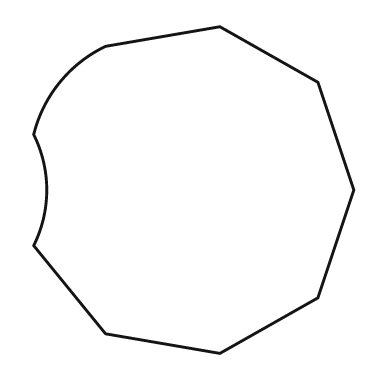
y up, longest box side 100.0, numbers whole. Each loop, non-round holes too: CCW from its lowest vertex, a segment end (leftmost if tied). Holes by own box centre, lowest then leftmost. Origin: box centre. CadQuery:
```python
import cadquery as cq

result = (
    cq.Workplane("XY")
    .moveTo(8.0, -50.0)
    .lineTo(38.0, -33.0)
    .lineTo(49.0, 0.0)
    .lineTo(38.0, 33.0)
    .lineTo(8.0, 50.0)
    .lineTo(-27.0, 44.0)
    .threePointArc((-41.0, 33.0), (-49.0, 17.0))
    .threePointArc((-45.0, 0.0), (-49.0, -17.0))
    .lineTo(-27.0, -44.0)
    .close()
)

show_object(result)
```